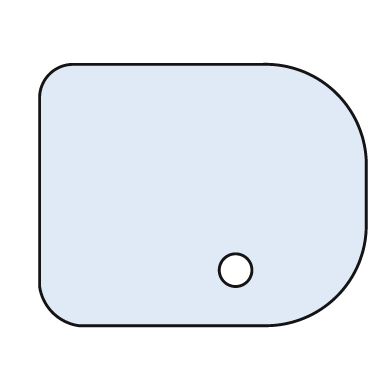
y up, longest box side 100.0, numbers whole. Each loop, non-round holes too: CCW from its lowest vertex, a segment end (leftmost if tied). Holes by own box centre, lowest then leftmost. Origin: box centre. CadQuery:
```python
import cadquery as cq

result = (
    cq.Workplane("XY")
    .moveTo(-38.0, -40.0)
    .lineTo(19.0, -40.0)
    .threePointArc((41.0, -31.0), (50.0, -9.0))
    .lineTo(50.0, 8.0)
    .threePointArc((41.0, 31.0), (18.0, 40.0))
    .lineTo(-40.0, 40.0)
    .threePointArc((-47.0, 37.0), (-50.0, 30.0))
    .lineTo(-50.0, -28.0)
    .threePointArc((-46.0, -36.0), (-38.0, -40.0))
    .close()
    .moveTo(10.0, -23.0)
    .circle(5.0)
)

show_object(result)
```